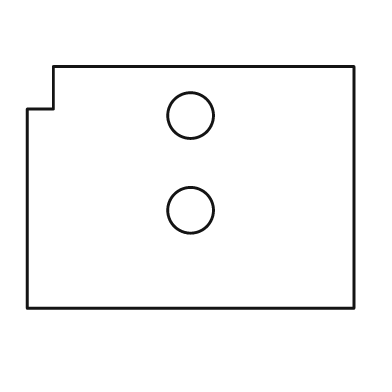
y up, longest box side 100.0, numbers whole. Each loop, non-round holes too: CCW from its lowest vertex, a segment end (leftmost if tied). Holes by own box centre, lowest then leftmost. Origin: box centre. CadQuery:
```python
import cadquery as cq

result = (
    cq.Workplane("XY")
    .moveTo(-50.0, -37.0)
    .lineTo(50.0, -37.0)
    .lineTo(50.0, 37.0)
    .lineTo(-42.0, 37.0)
    .lineTo(-42.0, 24.0)
    .lineTo(-50.0, 24.0)
    .close()
    .moveTo(0.0, -7.0)
    .circle(7.0)
    .moveTo(0.0, 22.0)
    .circle(7.0)
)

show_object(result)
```